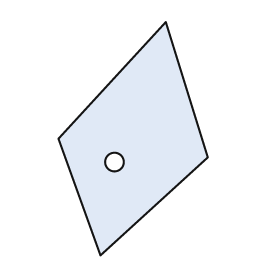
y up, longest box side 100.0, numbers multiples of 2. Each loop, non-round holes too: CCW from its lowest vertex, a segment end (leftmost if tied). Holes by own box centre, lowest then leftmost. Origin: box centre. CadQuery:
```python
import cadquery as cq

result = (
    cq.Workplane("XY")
    .moveTo(-14.0, -50.0)
    .lineTo(32.0, -8.0)
    .lineTo(14.0, 50.0)
    .lineTo(-32.0, 0.0)
    .close()
    .moveTo(-8.0, -10.0)
    .circle(4.0)
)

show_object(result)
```